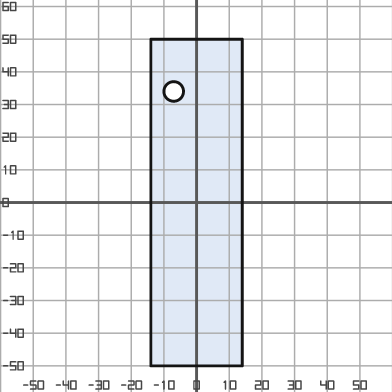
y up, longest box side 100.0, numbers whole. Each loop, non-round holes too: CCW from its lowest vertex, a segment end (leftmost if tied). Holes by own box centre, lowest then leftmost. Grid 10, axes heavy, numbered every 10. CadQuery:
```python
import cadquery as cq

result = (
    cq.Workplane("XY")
    .moveTo(-14.0, -50.0)
    .lineTo(14.0, -50.0)
    .lineTo(14.0, 50.0)
    .lineTo(-14.0, 50.0)
    .close()
    .moveTo(-7.0, 34.0)
    .circle(3.0)
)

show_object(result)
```